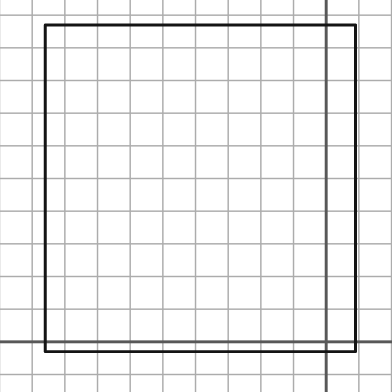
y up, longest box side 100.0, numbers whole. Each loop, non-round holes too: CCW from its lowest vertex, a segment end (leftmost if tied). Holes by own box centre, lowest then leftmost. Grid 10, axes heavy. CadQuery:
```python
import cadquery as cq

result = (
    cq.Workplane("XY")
    .moveTo(-86.0, -3.0)
    .lineTo(9.0, -3.0)
    .lineTo(9.0, 97.0)
    .lineTo(-86.0, 97.0)
    .close()
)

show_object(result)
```